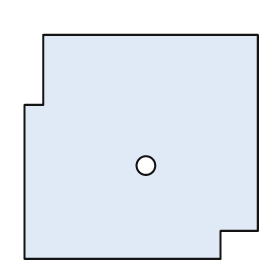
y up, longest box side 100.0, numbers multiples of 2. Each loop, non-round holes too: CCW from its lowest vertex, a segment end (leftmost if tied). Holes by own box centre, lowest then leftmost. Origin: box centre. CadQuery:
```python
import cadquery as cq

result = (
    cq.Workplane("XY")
    .moveTo(-50.0, -48.0)
    .lineTo(34.0, -48.0)
    .lineTo(34.0, -36.0)
    .lineTo(50.0, -36.0)
    .lineTo(50.0, 48.0)
    .lineTo(-42.0, 48.0)
    .lineTo(-42.0, 18.0)
    .lineTo(-50.0, 18.0)
    .close()
    .moveTo(2.0, -8.0)
    .circle(4.0)
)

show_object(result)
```